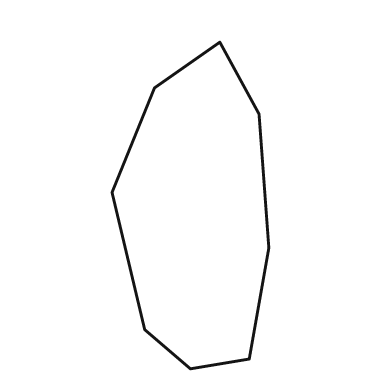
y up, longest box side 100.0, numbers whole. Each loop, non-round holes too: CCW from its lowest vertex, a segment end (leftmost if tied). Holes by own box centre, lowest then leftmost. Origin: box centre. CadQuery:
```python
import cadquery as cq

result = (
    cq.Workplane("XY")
    .moveTo(0.0, -50.0)
    .lineTo(18.0, -47.0)
    .lineTo(24.0, -13.0)
    .lineTo(21.0, 28.0)
    .lineTo(9.0, 50.0)
    .lineTo(-11.0, 36.0)
    .lineTo(-24.0, 4.0)
    .lineTo(-14.0, -38.0)
    .close()
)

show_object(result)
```